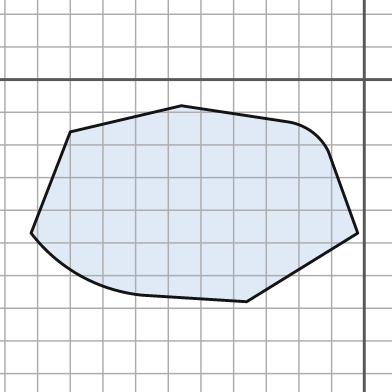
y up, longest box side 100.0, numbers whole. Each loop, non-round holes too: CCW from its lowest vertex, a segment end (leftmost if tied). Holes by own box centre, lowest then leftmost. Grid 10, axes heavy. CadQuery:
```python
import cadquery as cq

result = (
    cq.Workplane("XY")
    .moveTo(-36.0, -68.0)
    .lineTo(-2.0, -47.0)
    .lineTo(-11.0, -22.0)
    .threePointArc((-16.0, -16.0), (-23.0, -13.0))
    .lineTo(-56.0, -8.0)
    .lineTo(-90.0, -16.0)
    .lineTo(-102.0, -47.0)
    .threePointArc((-87.0, -60.0), (-68.0, -66.0))
    .close()
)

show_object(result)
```